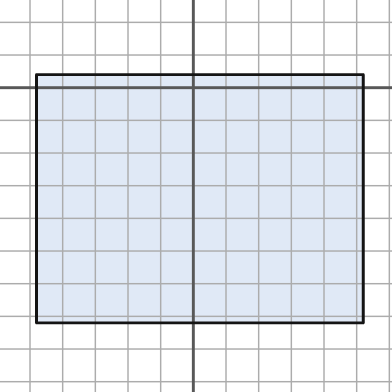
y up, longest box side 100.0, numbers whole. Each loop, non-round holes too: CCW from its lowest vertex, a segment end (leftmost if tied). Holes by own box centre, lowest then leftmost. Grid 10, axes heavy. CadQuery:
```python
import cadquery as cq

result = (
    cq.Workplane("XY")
    .moveTo(-48.0, -72.0)
    .lineTo(52.0, -72.0)
    .lineTo(52.0, 4.0)
    .lineTo(-48.0, 4.0)
    .close()
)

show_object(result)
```